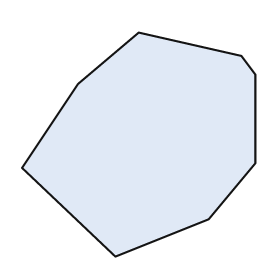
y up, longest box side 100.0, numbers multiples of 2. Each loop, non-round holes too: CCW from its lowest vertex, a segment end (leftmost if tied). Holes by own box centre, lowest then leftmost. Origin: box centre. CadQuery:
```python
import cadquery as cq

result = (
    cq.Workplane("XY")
    .moveTo(-10.0, -48.0)
    .lineTo(30.0, -32.0)
    .lineTo(50.0, -8.0)
    .lineTo(50.0, 30.0)
    .lineTo(44.0, 38.0)
    .lineTo(0.0, 48.0)
    .lineTo(-26.0, 26.0)
    .lineTo(-50.0, -10.0)
    .close()
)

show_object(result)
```